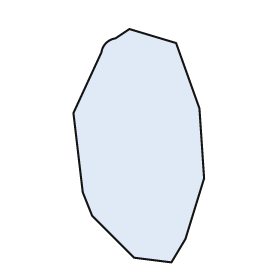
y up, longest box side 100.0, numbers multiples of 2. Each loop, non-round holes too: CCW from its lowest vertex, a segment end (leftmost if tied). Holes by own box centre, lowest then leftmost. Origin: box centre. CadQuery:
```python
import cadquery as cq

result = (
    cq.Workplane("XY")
    .moveTo(14.0, -50.0)
    .lineTo(20.0, -40.0)
    .lineTo(28.0, -14.0)
    .lineTo(26.0, 16.0)
    .lineTo(16.0, 44.0)
    .lineTo(-4.0, 50.0)
    .lineTo(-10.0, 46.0)
    .threePointArc((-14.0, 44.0), (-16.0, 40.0))
    .lineTo(-28.0, 14.0)
    .lineTo(-24.0, -20.0)
    .lineTo(-20.0, -30.0)
    .lineTo(-2.0, -48.0)
    .close()
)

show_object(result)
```